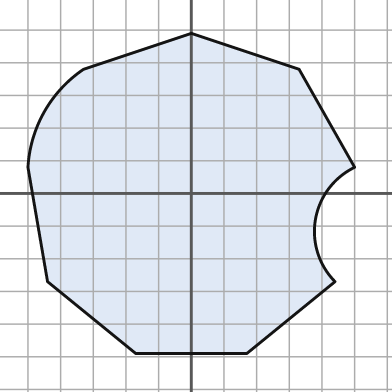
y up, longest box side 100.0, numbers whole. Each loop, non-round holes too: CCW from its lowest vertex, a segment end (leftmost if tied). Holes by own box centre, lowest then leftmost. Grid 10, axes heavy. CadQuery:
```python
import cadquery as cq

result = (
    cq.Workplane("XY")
    .moveTo(-17.0, -49.0)
    .lineTo(17.0, -49.0)
    .lineTo(44.0, -27.0)
    .threePointArc((38.0, -8.0), (50.0, 8.0))
    .lineTo(33.0, 38.0)
    .lineTo(0.0, 49.0)
    .lineTo(-33.0, 38.0)
    .threePointArc((-45.0, 25.0), (-50.0, 8.0))
    .lineTo(-44.0, -27.0)
    .close()
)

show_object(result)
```